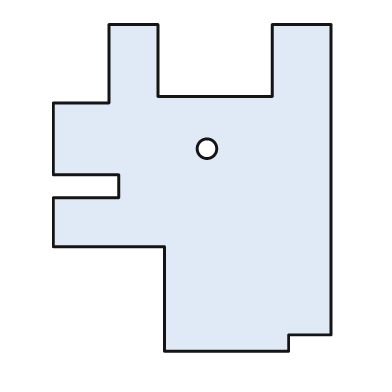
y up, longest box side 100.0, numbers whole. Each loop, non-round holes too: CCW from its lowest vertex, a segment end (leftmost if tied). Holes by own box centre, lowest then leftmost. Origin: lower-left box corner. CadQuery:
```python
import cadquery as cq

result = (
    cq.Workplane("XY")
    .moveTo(34.0, 0.0)
    .lineTo(72.0, 0.0)
    .lineTo(72.0, 5.0)
    .lineTo(85.0, 5.0)
    .lineTo(85.0, 100.0)
    .lineTo(67.0, 100.0)
    .lineTo(67.0, 78.0)
    .lineTo(32.0, 78.0)
    .lineTo(32.0, 100.0)
    .lineTo(17.0, 100.0)
    .lineTo(17.0, 76.0)
    .lineTo(0.0, 76.0)
    .lineTo(0.0, 54.0)
    .lineTo(20.0, 54.0)
    .lineTo(20.0, 47.0)
    .lineTo(0.0, 47.0)
    .lineTo(0.0, 32.0)
    .lineTo(34.0, 32.0)
    .close()
    .moveTo(47.0, 62.0)
    .circle(3.0)
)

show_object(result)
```